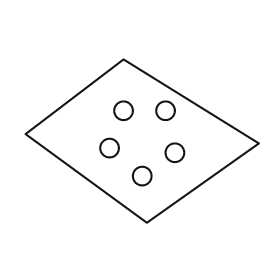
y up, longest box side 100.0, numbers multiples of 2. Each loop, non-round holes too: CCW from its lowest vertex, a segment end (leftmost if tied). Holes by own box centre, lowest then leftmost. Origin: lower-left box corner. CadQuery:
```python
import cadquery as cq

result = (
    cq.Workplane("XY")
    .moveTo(52.0, 0.0)
    .lineTo(100.0, 34.0)
    .lineTo(42.0, 70.0)
    .lineTo(0.0, 38.0)
    .close()
    .moveTo(50.0, 20.0)
    .circle(4.0)
    .moveTo(64.0, 30.0)
    .circle(4.0)
    .moveTo(36.0, 32.0)
    .circle(4.0)
    .moveTo(42.0, 48.0)
    .circle(4.0)
    .moveTo(60.0, 48.0)
    .circle(4.0)
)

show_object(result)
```